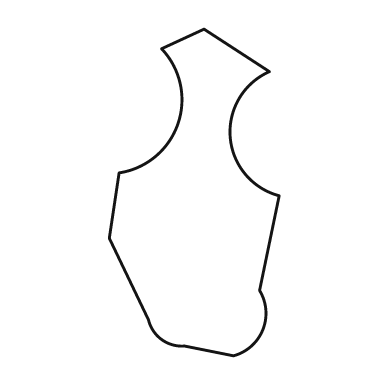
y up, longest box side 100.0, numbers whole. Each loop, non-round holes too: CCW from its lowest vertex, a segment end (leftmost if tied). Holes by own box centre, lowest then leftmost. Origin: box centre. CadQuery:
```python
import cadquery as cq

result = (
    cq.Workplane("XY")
    .moveTo(12.0, -50.0)
    .threePointArc((21.0, -42.0), (20.0, -30.0))
    .lineTo(26.0, -1.0)
    .threePointArc((11.0, 17.0), (23.0, 37.0))
    .lineTo(3.0, 50.0)
    .lineTo(-10.0, 44.0)
    .threePointArc((-5.0, 21.0), (-23.0, 6.0))
    .lineTo(-26.0, -14.0)
    .lineTo(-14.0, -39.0)
    .threePointArc((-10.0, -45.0), (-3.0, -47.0))
    .close()
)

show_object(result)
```